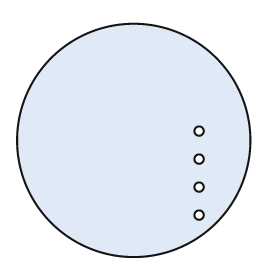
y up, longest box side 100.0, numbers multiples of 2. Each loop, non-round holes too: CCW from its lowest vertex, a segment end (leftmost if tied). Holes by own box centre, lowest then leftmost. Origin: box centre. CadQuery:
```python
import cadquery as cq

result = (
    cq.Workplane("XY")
    .moveTo(0.0, 0.0)
    .circle(50.0)
    .moveTo(28.0, -32.0)
    .circle(2.0)
    .moveTo(28.0, -20.0)
    .circle(2.0)
    .moveTo(28.0, -8.0)
    .circle(2.0)
    .moveTo(28.0, 4.0)
    .circle(2.0)
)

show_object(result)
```